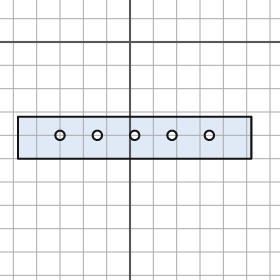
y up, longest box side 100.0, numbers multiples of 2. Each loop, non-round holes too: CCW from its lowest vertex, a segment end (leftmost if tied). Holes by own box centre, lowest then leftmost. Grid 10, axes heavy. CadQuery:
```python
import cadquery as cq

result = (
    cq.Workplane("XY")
    .moveTo(-48.0, -50.0)
    .lineTo(52.0, -50.0)
    .lineTo(52.0, -32.0)
    .lineTo(-48.0, -32.0)
    .close()
    .moveTo(-30.0, -40.0)
    .circle(2.0)
    .moveTo(-14.0, -40.0)
    .circle(2.0)
    .moveTo(2.0, -40.0)
    .circle(2.0)
    .moveTo(18.0, -40.0)
    .circle(2.0)
    .moveTo(34.0, -40.0)
    .circle(2.0)
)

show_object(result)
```